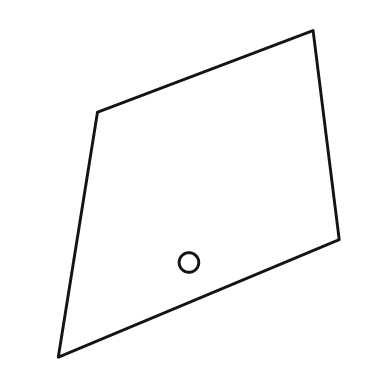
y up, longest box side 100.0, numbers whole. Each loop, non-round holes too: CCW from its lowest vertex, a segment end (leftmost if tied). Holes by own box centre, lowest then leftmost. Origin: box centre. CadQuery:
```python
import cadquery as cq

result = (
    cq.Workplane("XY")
    .moveTo(-43.0, -50.0)
    .lineTo(43.0, -14.0)
    .lineTo(35.0, 50.0)
    .lineTo(-31.0, 25.0)
    .close()
    .moveTo(-3.0, -21.0)
    .circle(3.0)
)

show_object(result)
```